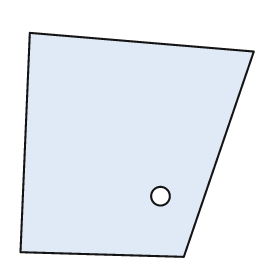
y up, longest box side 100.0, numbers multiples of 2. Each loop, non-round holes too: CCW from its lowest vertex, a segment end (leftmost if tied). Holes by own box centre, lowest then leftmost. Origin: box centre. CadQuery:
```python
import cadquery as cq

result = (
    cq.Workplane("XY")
    .moveTo(20.0, -48.0)
    .lineTo(50.0, 40.0)
    .lineTo(-46.0, 48.0)
    .lineTo(-50.0, -46.0)
    .close()
    .moveTo(10.0, -22.0)
    .circle(4.0)
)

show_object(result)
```